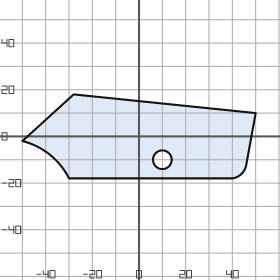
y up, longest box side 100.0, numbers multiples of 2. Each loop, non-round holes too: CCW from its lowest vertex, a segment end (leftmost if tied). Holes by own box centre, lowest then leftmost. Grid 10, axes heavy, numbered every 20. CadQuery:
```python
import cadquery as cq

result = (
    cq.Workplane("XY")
    .moveTo(-30.0, -18.0)
    .lineTo(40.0, -18.0)
    .threePointArc((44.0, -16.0), (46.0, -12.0))
    .lineTo(50.0, 10.0)
    .lineTo(-28.0, 18.0)
    .lineTo(-50.0, -2.0)
    .threePointArc((-38.0, -8.0), (-30.0, -18.0))
    .close()
    .moveTo(10.0, -10.0)
    .circle(4.0)
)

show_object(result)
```